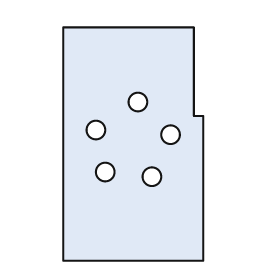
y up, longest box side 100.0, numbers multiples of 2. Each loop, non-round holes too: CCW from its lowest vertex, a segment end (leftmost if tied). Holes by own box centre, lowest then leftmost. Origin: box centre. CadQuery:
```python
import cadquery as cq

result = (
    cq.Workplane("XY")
    .moveTo(-30.0, -50.0)
    .lineTo(30.0, -50.0)
    .lineTo(30.0, 12.0)
    .lineTo(26.0, 12.0)
    .lineTo(26.0, 50.0)
    .lineTo(-30.0, 50.0)
    .close()
    .moveTo(8.0, -14.0)
    .circle(4.0)
    .moveTo(-12.0, -12.0)
    .circle(4.0)
    .moveTo(16.0, 4.0)
    .circle(4.0)
    .moveTo(-16.0, 6.0)
    .circle(4.0)
    .moveTo(2.0, 18.0)
    .circle(4.0)
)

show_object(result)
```